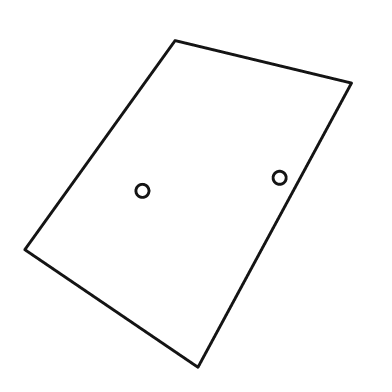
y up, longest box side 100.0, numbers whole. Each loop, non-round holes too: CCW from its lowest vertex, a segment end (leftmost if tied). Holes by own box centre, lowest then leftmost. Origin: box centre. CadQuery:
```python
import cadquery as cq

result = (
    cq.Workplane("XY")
    .moveTo(3.0, -50.0)
    .lineTo(50.0, 37.0)
    .lineTo(-4.0, 50.0)
    .lineTo(-50.0, -14.0)
    .close()
    .moveTo(-14.0, 4.0)
    .circle(2.0)
    .moveTo(28.0, 8.0)
    .circle(2.0)
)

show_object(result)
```